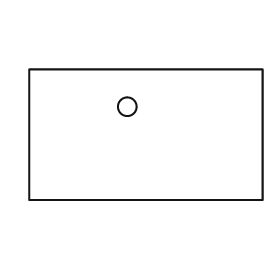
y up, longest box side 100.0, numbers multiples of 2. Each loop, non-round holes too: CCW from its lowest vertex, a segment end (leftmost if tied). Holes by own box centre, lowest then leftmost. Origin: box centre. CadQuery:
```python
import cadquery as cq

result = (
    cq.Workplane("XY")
    .moveTo(-50.0, -28.0)
    .lineTo(50.0, -28.0)
    .lineTo(50.0, 28.0)
    .lineTo(-50.0, 28.0)
    .close()
    .moveTo(-8.0, 12.0)
    .circle(4.0)
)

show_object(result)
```